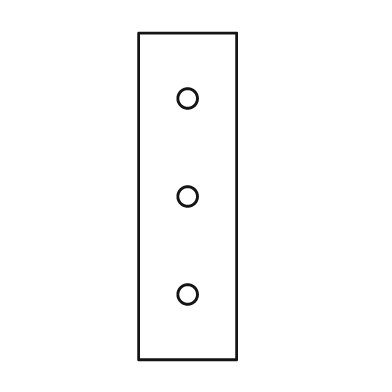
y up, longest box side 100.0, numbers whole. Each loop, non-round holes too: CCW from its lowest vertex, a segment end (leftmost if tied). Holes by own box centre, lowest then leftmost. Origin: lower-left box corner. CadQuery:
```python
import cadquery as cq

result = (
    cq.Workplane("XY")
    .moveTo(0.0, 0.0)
    .lineTo(30.0, 0.0)
    .lineTo(30.0, 100.0)
    .lineTo(0.0, 100.0)
    .close()
    .moveTo(15.0, 20.0)
    .circle(3.0)
    .moveTo(15.0, 50.0)
    .circle(3.0)
    .moveTo(15.0, 80.0)
    .circle(3.0)
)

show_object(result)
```